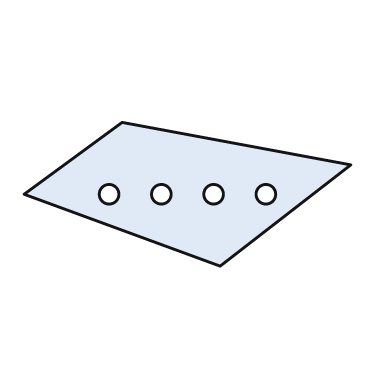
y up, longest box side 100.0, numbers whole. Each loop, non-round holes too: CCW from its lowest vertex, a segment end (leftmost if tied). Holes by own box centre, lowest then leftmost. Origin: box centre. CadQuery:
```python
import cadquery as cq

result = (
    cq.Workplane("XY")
    .moveTo(10.0, -22.0)
    .lineTo(50.0, 9.0)
    .lineTo(-20.0, 22.0)
    .lineTo(-50.0, 0.0)
    .close()
    .moveTo(-24.0, 0.0)
    .circle(3.0)
    .moveTo(-8.0, 0.0)
    .circle(3.0)
    .moveTo(8.0, 0.0)
    .circle(3.0)
    .moveTo(24.0, 0.0)
    .circle(3.0)
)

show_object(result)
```